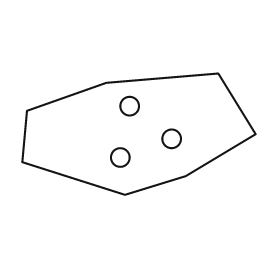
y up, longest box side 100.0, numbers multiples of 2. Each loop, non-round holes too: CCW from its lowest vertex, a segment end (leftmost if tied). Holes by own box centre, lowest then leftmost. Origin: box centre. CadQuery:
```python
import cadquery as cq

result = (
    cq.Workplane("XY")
    .moveTo(-6.0, -26.0)
    .lineTo(20.0, -18.0)
    .lineTo(50.0, 0.0)
    .lineTo(34.0, 26.0)
    .lineTo(-14.0, 22.0)
    .lineTo(-48.0, 10.0)
    .lineTo(-50.0, -12.0)
    .close()
    .moveTo(-8.0, -10.0)
    .circle(4.0)
    .moveTo(14.0, -2.0)
    .circle(4.0)
    .moveTo(-4.0, 12.0)
    .circle(4.0)
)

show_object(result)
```